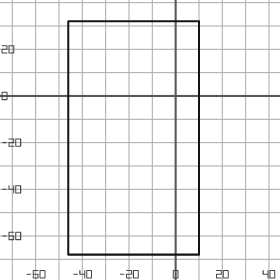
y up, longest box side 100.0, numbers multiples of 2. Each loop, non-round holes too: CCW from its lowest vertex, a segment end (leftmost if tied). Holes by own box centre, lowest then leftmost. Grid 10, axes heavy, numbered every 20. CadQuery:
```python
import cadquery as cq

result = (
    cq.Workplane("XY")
    .moveTo(-46.0, -68.0)
    .lineTo(10.0, -68.0)
    .lineTo(10.0, 32.0)
    .lineTo(-46.0, 32.0)
    .close()
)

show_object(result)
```